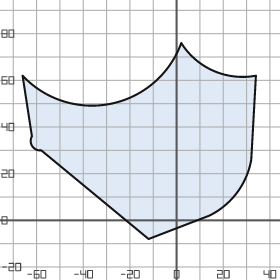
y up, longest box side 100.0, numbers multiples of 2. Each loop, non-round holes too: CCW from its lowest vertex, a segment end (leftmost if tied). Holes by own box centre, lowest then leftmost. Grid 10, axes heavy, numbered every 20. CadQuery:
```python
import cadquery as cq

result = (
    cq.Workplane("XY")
    .moveTo(-12.0, -8.0)
    .lineTo(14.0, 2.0)
    .threePointArc((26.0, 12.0), (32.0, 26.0))
    .lineTo(34.0, 62.0)
    .threePointArc((16.0, 64.0), (2.0, 76.0))
    .threePointArc((-28.0, 50.0), (-66.0, 62.0))
    .lineTo(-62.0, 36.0)
    .threePointArc((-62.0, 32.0), (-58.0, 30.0))
    .close()
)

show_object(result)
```